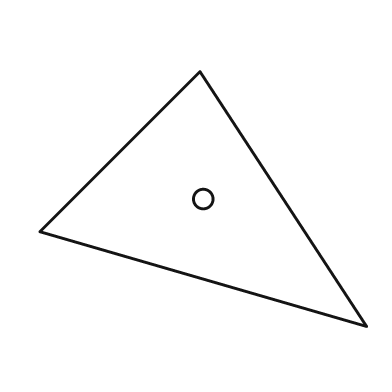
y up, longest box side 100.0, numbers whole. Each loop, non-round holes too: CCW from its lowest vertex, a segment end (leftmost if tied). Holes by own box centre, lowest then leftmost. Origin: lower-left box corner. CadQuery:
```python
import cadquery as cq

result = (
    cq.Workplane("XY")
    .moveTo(100.0, 0.0)
    .lineTo(49.0, 78.0)
    .lineTo(0.0, 29.0)
    .close()
    .moveTo(50.0, 39.0)
    .circle(3.0)
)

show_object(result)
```